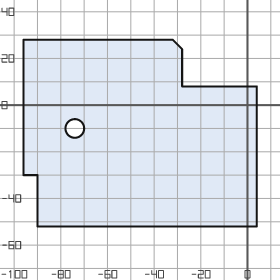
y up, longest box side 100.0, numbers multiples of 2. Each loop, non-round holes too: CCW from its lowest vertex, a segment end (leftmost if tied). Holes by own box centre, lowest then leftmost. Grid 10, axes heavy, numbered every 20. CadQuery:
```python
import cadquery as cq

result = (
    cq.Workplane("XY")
    .moveTo(-90.0, -52.0)
    .lineTo(4.0, -52.0)
    .lineTo(4.0, 8.0)
    .lineTo(-28.0, 8.0)
    .lineTo(-28.0, 24.0)
    .lineTo(-32.0, 28.0)
    .lineTo(-96.0, 28.0)
    .lineTo(-96.0, -30.0)
    .lineTo(-90.0, -30.0)
    .close()
    .moveTo(-74.0, -10.0)
    .circle(4.0)
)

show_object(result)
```